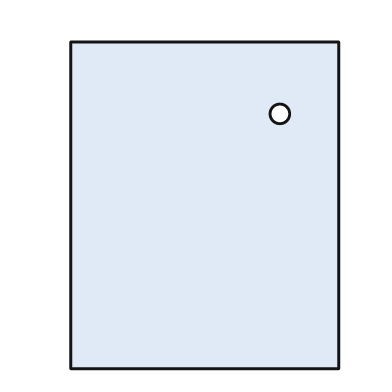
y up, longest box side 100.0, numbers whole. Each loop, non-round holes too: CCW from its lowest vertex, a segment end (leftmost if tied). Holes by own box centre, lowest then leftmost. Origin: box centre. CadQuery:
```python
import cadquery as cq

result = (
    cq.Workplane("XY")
    .moveTo(-41.0, -50.0)
    .lineTo(41.0, -50.0)
    .lineTo(41.0, 50.0)
    .lineTo(-41.0, 50.0)
    .close()
    .moveTo(23.0, 28.0)
    .circle(3.0)
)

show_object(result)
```